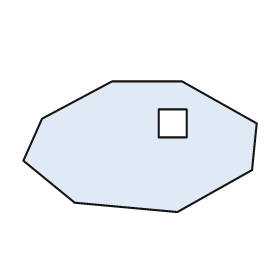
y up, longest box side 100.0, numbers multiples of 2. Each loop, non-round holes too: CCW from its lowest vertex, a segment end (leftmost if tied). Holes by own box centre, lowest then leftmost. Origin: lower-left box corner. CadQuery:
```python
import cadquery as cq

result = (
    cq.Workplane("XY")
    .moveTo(66.0, 0.0)
    .lineTo(98.0, 18.0)
    .lineTo(100.0, 38.0)
    .lineTo(68.0, 56.0)
    .lineTo(38.0, 56.0)
    .lineTo(8.0, 40.0)
    .lineTo(0.0, 22.0)
    .lineTo(22.0, 4.0)
    .close()
    .moveTo(58.0, 32.0)
    .lineTo(70.0, 32.0)
    .lineTo(70.0, 44.0)
    .lineTo(58.0, 44.0)
    .close()
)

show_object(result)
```